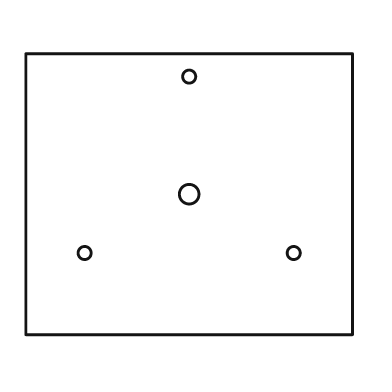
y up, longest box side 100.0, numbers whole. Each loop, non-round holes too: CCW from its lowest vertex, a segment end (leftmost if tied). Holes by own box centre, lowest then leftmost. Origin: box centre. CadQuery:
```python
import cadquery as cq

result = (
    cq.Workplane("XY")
    .moveTo(-50.0, -43.0)
    .lineTo(50.0, -43.0)
    .lineTo(50.0, 43.0)
    .lineTo(-50.0, 43.0)
    .close()
    .moveTo(-32.0, -18.0)
    .circle(2.0)
    .moveTo(32.0, -18.0)
    .circle(2.0)
    .moveTo(0.0, 0.0)
    .circle(3.0)
    .moveTo(0.0, 36.0)
    .circle(2.0)
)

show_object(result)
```